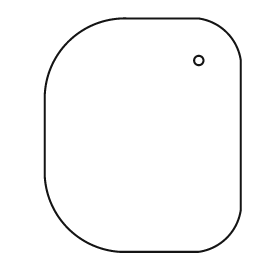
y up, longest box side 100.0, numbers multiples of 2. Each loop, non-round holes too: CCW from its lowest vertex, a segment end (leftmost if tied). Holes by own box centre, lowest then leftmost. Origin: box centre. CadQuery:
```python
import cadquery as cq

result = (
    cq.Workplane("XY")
    .moveTo(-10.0, -50.0)
    .lineTo(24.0, -50.0)
    .threePointArc((36.0, -44.0), (42.0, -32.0))
    .lineTo(42.0, 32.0)
    .threePointArc((36.0, 44.0), (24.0, 50.0))
    .lineTo(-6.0, 50.0)
    .threePointArc((-32.0, 40.0), (-42.0, 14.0))
    .lineTo(-42.0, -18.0)
    .threePointArc((-32.0, -40.0), (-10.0, -50.0))
    .close()
    .moveTo(24.0, 32.0)
    .circle(2.0)
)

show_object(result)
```